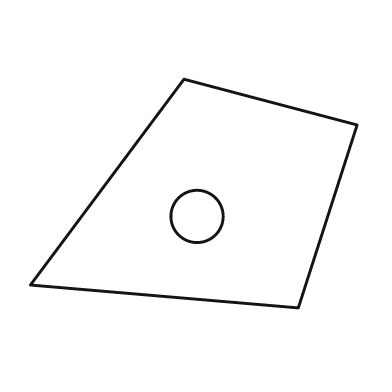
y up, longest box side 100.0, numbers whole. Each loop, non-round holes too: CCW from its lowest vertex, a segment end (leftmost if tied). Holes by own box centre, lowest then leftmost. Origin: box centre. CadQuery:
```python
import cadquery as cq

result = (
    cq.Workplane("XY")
    .moveTo(32.0, -35.0)
    .lineTo(50.0, 21.0)
    .lineTo(-3.0, 35.0)
    .lineTo(-50.0, -28.0)
    .close()
    .moveTo(1.0, -7.0)
    .circle(8.0)
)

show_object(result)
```